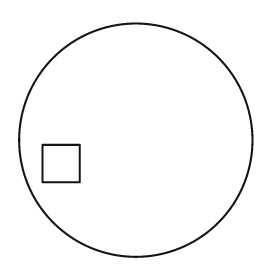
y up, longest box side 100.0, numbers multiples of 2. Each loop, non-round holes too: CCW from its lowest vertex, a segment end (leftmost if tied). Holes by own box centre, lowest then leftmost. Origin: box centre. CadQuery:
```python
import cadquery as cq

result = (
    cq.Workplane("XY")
    .moveTo(0.0, 0.0)
    .circle(50.0)
    .moveTo(-40.0, -18.0)
    .lineTo(-24.0, -18.0)
    .lineTo(-24.0, -2.0)
    .lineTo(-40.0, -2.0)
    .close()
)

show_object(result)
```